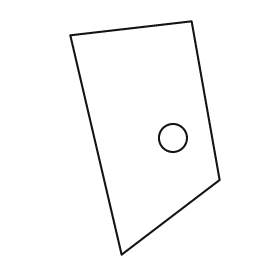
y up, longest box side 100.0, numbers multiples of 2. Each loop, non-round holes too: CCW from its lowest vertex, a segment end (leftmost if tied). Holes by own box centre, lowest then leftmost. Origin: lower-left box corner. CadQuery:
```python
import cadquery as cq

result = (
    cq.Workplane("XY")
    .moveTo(22.0, 0.0)
    .lineTo(64.0, 32.0)
    .lineTo(52.0, 100.0)
    .lineTo(0.0, 94.0)
    .close()
    .moveTo(44.0, 50.0)
    .circle(6.0)
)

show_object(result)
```